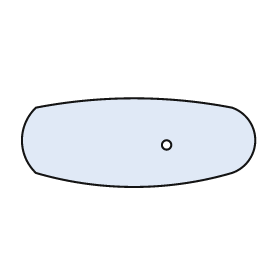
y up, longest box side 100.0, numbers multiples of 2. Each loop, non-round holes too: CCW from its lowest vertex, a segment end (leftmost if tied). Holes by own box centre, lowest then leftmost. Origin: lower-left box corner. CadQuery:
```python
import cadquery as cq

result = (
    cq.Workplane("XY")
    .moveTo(6.0, 6.0)
    .threePointArc((48.0, 0.0), (90.0, 6.0))
    .threePointArc((100.0, 20.0), (90.0, 34.0))
    .threePointArc((48.0, 38.0), (6.0, 34.0))
    .threePointArc((0.0, 20.0), (6.0, 6.0))
    .close()
    .moveTo(62.0, 18.0)
    .circle(2.0)
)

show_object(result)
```